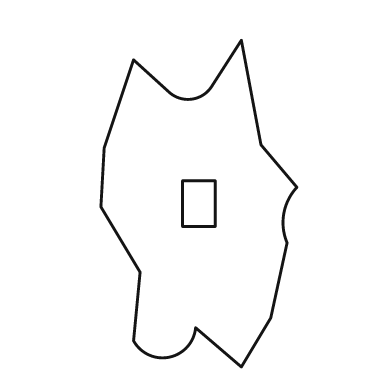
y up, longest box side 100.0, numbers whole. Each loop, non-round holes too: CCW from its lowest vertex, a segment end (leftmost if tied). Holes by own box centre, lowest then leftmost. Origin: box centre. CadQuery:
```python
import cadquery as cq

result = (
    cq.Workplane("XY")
    .moveTo(13.0, -50.0)
    .lineTo(22.0, -35.0)
    .lineTo(27.0, -12.0)
    .threePointArc((26.0, -3.0), (30.0, 5.0))
    .lineTo(19.0, 18.0)
    .lineTo(13.0, 50.0)
    .lineTo(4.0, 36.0)
    .threePointArc((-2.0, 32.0), (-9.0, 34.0))
    .lineTo(-20.0, 44.0)
    .lineTo(-29.0, 17.0)
    .lineTo(-30.0, -1.0)
    .lineTo(-18.0, -21.0)
    .lineTo(-20.0, -42.0)
    .threePointArc((-9.0, -47.0), (-1.0, -38.0))
    .close()
    .moveTo(-5.0, -7.0)
    .lineTo(5.0, -7.0)
    .lineTo(5.0, 7.0)
    .lineTo(-5.0, 7.0)
    .close()
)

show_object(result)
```